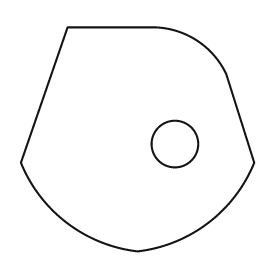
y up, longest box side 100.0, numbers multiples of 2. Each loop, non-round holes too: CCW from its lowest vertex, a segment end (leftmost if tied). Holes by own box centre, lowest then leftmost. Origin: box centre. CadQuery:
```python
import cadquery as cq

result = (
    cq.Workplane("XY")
    .moveTo(0.0, -48.0)
    .threePointArc((30.0, -36.0), (50.0, -10.0))
    .lineTo(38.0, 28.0)
    .threePointArc((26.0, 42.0), (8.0, 48.0))
    .lineTo(-30.0, 48.0)
    .lineTo(-50.0, -10.0)
    .threePointArc((-30.0, -36.0), (0.0, -48.0))
    .close()
    .moveTo(16.0, -2.0)
    .circle(10.0)
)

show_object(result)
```